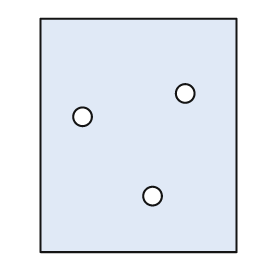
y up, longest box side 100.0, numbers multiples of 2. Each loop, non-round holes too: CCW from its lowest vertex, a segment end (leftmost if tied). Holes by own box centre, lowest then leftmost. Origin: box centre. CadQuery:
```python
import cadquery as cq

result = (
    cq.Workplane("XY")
    .moveTo(-42.0, -50.0)
    .lineTo(42.0, -50.0)
    .lineTo(42.0, 50.0)
    .lineTo(-42.0, 50.0)
    .close()
    .moveTo(6.0, -26.0)
    .circle(4.0)
    .moveTo(-24.0, 8.0)
    .circle(4.0)
    .moveTo(20.0, 18.0)
    .circle(4.0)
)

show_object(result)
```